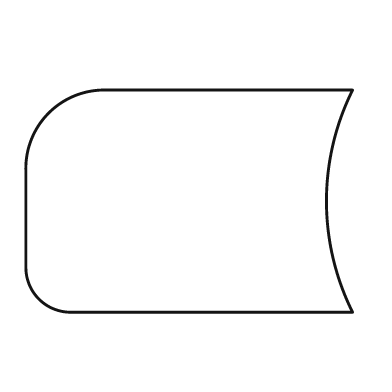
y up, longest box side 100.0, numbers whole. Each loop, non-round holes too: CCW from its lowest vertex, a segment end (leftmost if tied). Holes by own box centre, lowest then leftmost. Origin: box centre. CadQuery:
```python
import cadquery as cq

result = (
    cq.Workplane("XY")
    .moveTo(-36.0, -34.0)
    .lineTo(50.0, -34.0)
    .threePointArc((42.0, 0.0), (50.0, 34.0))
    .lineTo(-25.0, 34.0)
    .threePointArc((-43.0, 27.0), (-50.0, 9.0))
    .lineTo(-50.0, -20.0)
    .threePointArc((-46.0, -30.0), (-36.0, -34.0))
    .close()
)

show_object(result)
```